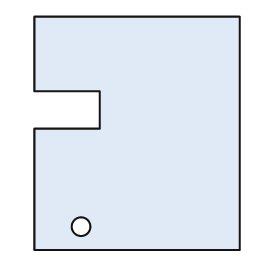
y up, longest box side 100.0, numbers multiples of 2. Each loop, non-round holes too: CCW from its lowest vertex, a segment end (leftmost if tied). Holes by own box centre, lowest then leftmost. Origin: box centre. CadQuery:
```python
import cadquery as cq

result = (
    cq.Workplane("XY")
    .moveTo(-44.0, -50.0)
    .lineTo(44.0, -50.0)
    .lineTo(44.0, 50.0)
    .lineTo(-44.0, 50.0)
    .lineTo(-44.0, 18.0)
    .lineTo(-16.0, 18.0)
    .lineTo(-16.0, 2.0)
    .lineTo(-44.0, 2.0)
    .close()
    .moveTo(-24.0, -40.0)
    .circle(4.0)
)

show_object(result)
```